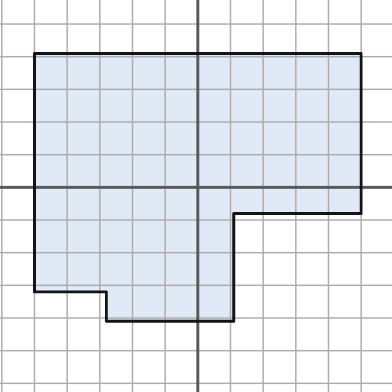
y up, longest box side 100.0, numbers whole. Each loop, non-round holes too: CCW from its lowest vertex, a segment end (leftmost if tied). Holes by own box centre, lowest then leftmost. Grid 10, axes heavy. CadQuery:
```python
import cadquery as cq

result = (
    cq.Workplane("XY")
    .moveTo(-28.0, -41.0)
    .lineTo(11.0, -41.0)
    .lineTo(11.0, -8.0)
    .lineTo(50.0, -8.0)
    .lineTo(50.0, 41.0)
    .lineTo(-50.0, 41.0)
    .lineTo(-50.0, -32.0)
    .lineTo(-28.0, -32.0)
    .close()
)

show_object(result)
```